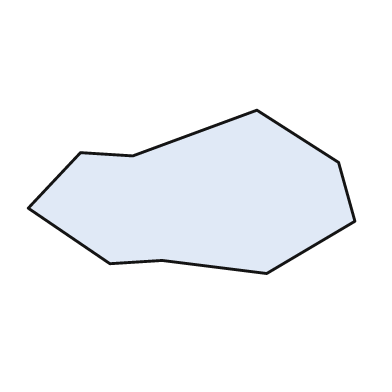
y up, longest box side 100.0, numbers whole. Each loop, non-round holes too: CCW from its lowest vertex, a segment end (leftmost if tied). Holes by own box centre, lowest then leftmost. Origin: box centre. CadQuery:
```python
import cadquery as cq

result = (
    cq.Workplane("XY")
    .moveTo(23.0, -25.0)
    .lineTo(50.0, -9.0)
    .lineTo(45.0, 9.0)
    .lineTo(20.0, 25.0)
    .lineTo(-18.0, 11.0)
    .lineTo(-34.0, 12.0)
    .lineTo(-50.0, -5.0)
    .lineTo(-25.0, -22.0)
    .lineTo(-9.0, -21.0)
    .close()
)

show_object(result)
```